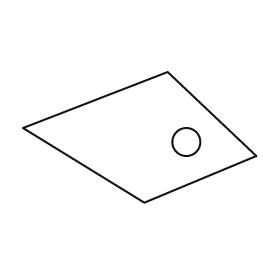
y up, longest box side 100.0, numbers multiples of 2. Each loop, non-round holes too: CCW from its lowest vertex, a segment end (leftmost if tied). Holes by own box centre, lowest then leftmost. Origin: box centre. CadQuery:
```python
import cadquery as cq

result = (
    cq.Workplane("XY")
    .moveTo(2.0, -28.0)
    .lineTo(50.0, -8.0)
    .lineTo(12.0, 28.0)
    .lineTo(-50.0, 4.0)
    .close()
    .moveTo(20.0, -2.0)
    .circle(6.0)
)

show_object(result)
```